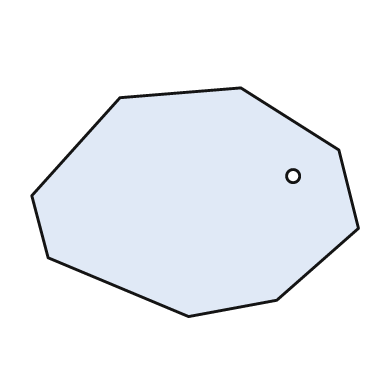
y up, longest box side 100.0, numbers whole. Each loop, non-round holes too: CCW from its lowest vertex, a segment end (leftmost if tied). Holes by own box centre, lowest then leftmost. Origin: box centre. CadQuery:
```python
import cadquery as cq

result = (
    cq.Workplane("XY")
    .moveTo(-2.0, -35.0)
    .lineTo(25.0, -30.0)
    .lineTo(50.0, -8.0)
    .lineTo(44.0, 16.0)
    .lineTo(14.0, 35.0)
    .lineTo(-23.0, 32.0)
    .lineTo(-50.0, 2.0)
    .lineTo(-45.0, -17.0)
    .close()
    .moveTo(30.0, 8.0)
    .circle(2.0)
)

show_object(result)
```